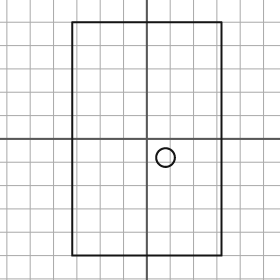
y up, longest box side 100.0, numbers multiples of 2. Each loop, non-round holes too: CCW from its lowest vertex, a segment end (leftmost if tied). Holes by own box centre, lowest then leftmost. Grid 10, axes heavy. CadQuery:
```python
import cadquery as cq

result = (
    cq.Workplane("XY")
    .moveTo(-32.0, -50.0)
    .lineTo(32.0, -50.0)
    .lineTo(32.0, 50.0)
    .lineTo(-32.0, 50.0)
    .close()
    .moveTo(8.0, -8.0)
    .circle(4.0)
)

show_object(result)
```